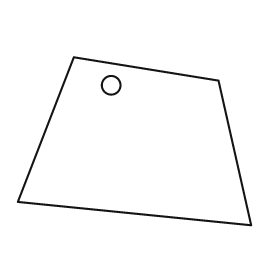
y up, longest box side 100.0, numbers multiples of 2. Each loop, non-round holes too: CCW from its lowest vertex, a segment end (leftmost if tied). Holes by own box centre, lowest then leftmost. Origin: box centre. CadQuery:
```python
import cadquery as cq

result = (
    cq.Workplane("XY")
    .moveTo(50.0, -36.0)
    .lineTo(36.0, 26.0)
    .lineTo(-26.0, 36.0)
    .lineTo(-50.0, -26.0)
    .close()
    .moveTo(-10.0, 24.0)
    .circle(4.0)
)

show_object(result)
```